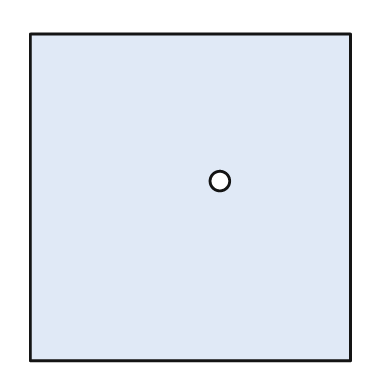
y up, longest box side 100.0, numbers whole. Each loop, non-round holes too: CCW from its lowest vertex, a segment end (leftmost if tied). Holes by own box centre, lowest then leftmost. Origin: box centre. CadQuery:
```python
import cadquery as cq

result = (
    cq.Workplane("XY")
    .moveTo(-49.0, -50.0)
    .lineTo(49.0, -50.0)
    .lineTo(49.0, 50.0)
    .lineTo(-49.0, 50.0)
    .close()
    .moveTo(9.0, 5.0)
    .circle(3.0)
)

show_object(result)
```